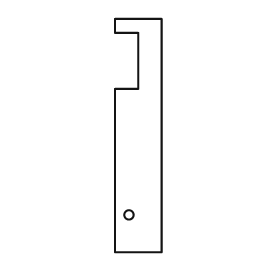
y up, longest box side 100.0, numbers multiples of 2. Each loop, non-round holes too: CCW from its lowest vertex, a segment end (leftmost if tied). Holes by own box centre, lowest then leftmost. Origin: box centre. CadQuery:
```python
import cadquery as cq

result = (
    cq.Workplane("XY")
    .moveTo(-10.0, -50.0)
    .lineTo(10.0, -50.0)
    .lineTo(10.0, 50.0)
    .lineTo(-10.0, 50.0)
    .lineTo(-10.0, 44.0)
    .lineTo(0.0, 44.0)
    .lineTo(0.0, 20.0)
    .lineTo(-10.0, 20.0)
    .close()
    .moveTo(-4.0, -34.0)
    .circle(2.0)
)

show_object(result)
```